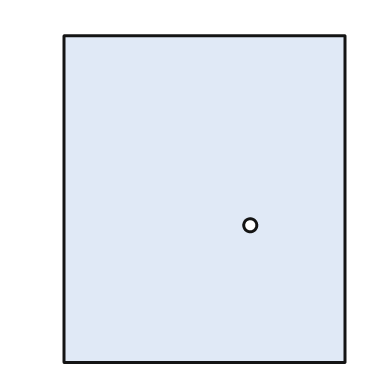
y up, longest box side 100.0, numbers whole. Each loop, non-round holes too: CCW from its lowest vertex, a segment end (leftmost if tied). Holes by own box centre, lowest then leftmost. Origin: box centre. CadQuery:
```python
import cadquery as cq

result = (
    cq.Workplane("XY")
    .moveTo(-43.0, -50.0)
    .lineTo(43.0, -50.0)
    .lineTo(43.0, 50.0)
    .lineTo(-43.0, 50.0)
    .close()
    .moveTo(14.0, -8.0)
    .circle(2.0)
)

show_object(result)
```